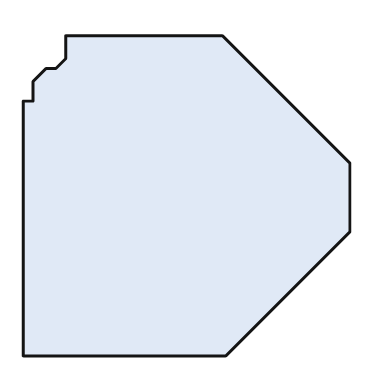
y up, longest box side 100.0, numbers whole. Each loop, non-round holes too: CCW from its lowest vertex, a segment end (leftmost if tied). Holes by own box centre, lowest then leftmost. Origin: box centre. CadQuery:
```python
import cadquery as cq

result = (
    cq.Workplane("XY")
    .moveTo(-50.0, -49.0)
    .lineTo(12.0, -49.0)
    .lineTo(50.0, -11.0)
    .lineTo(50.0, 10.0)
    .lineTo(11.0, 49.0)
    .lineTo(-37.0, 49.0)
    .lineTo(-37.0, 42.0)
    .lineTo(-40.0, 39.0)
    .lineTo(-43.0, 39.0)
    .lineTo(-47.0, 35.0)
    .lineTo(-47.0, 29.0)
    .lineTo(-50.0, 29.0)
    .close()
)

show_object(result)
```